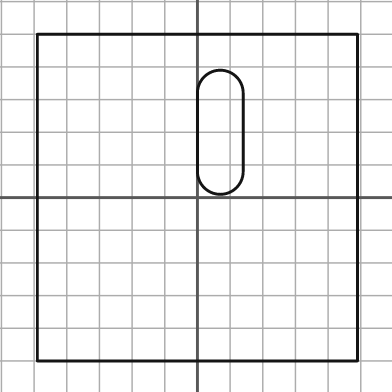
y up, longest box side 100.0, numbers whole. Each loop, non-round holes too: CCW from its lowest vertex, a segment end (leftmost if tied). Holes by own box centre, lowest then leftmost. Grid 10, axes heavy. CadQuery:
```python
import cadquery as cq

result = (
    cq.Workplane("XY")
    .moveTo(-49.0, -50.0)
    .lineTo(49.0, -50.0)
    .lineTo(49.0, 50.0)
    .lineTo(-49.0, 50.0)
    .close()
    .moveTo(0.0, 8.0)
    .threePointArc((7.0, 1.0), (14.0, 8.0))
    .lineTo(14.0, 32.0)
    .threePointArc((7.0, 39.0), (0.0, 32.0))
    .close()
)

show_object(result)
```